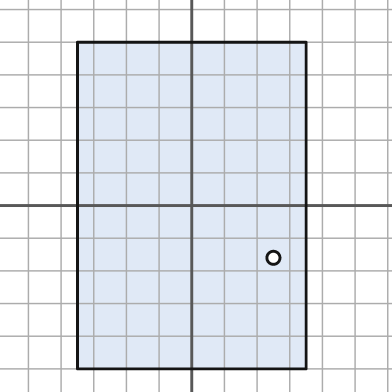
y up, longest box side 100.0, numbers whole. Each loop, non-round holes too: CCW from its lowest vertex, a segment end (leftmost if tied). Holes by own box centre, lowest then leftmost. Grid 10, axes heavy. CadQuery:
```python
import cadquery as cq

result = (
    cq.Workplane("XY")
    .moveTo(-35.0, -50.0)
    .lineTo(35.0, -50.0)
    .lineTo(35.0, 50.0)
    .lineTo(-35.0, 50.0)
    .close()
    .moveTo(25.0, -16.0)
    .circle(2.0)
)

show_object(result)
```